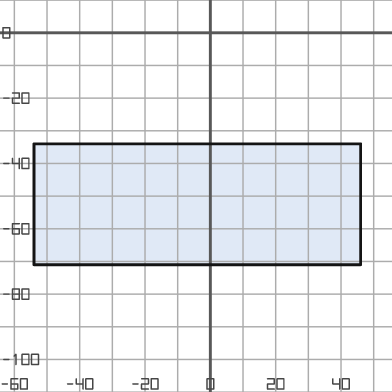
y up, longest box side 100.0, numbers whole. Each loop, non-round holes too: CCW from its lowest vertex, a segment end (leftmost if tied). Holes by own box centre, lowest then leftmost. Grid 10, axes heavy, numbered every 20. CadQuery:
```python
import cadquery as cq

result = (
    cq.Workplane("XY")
    .moveTo(-54.0, -71.0)
    .lineTo(46.0, -71.0)
    .lineTo(46.0, -34.0)
    .lineTo(-54.0, -34.0)
    .close()
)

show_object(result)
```